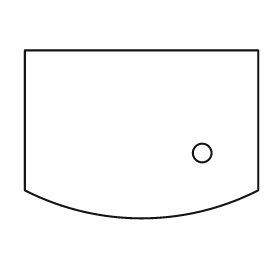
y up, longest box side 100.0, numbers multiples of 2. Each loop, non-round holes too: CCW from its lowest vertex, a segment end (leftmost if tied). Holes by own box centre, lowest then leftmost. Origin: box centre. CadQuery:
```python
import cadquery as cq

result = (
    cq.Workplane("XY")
    .moveTo(-50.0, -24.0)
    .threePointArc((0.0, -36.0), (50.0, -24.0))
    .lineTo(50.0, 36.0)
    .lineTo(-50.0, 36.0)
    .close()
    .moveTo(26.0, -8.0)
    .circle(4.0)
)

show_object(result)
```